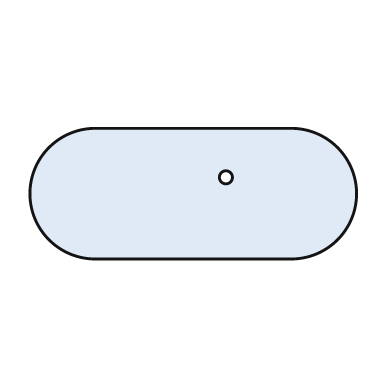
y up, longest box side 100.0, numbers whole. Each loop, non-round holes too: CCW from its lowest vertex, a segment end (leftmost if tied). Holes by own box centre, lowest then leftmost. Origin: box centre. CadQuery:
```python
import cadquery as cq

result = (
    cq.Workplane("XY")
    .moveTo(-30.0, -20.0)
    .lineTo(30.0, -20.0)
    .threePointArc((50.0, 0.0), (30.0, 20.0))
    .lineTo(-30.0, 20.0)
    .threePointArc((-50.0, 0.0), (-30.0, -20.0))
    .close()
    .moveTo(10.0, 5.0)
    .circle(2.0)
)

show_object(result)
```